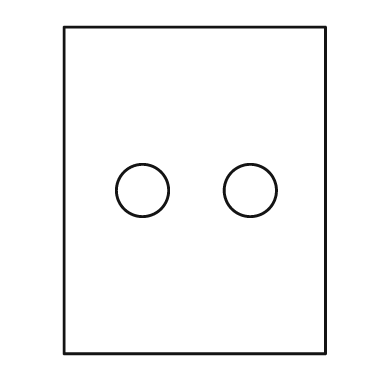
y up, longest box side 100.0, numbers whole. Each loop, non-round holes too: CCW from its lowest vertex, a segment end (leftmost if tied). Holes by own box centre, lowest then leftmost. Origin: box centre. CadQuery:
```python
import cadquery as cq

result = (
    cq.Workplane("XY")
    .moveTo(-40.0, -50.0)
    .lineTo(40.0, -50.0)
    .lineTo(40.0, 50.0)
    .lineTo(-40.0, 50.0)
    .close()
    .moveTo(-16.0, 0.0)
    .circle(8.0)
    .moveTo(17.0, 0.0)
    .circle(8.0)
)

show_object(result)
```